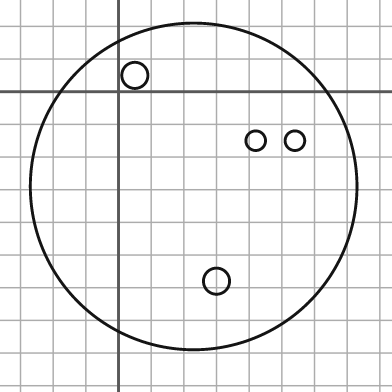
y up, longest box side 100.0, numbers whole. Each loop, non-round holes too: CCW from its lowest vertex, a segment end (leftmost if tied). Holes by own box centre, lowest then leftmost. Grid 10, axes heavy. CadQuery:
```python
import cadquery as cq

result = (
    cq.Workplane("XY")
    .moveTo(23.0, -29.0)
    .circle(50.0)
    .moveTo(30.0, -58.0)
    .circle(4.0)
    .moveTo(42.0, -15.0)
    .circle(3.0)
    .moveTo(54.0, -15.0)
    .circle(3.0)
    .moveTo(5.0, 5.0)
    .circle(4.0)
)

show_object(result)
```